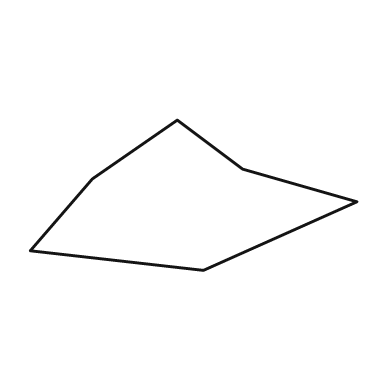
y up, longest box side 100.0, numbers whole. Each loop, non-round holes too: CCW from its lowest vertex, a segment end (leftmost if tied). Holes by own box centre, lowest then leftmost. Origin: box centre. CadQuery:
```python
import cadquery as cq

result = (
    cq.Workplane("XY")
    .moveTo(3.0, -23.0)
    .lineTo(50.0, -2.0)
    .lineTo(15.0, 8.0)
    .lineTo(-5.0, 23.0)
    .lineTo(-31.0, 5.0)
    .lineTo(-50.0, -17.0)
    .close()
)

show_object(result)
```